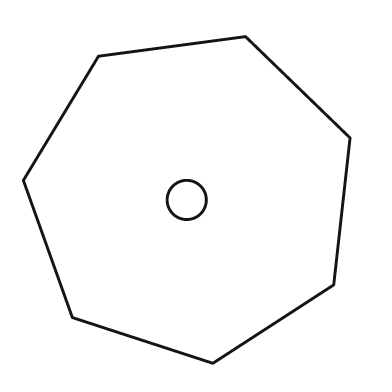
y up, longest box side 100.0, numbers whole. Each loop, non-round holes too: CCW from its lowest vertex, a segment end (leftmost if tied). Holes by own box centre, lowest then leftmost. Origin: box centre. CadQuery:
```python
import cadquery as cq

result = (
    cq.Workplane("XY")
    .moveTo(8.0, -50.0)
    .lineTo(45.0, -26.0)
    .lineTo(50.0, 19.0)
    .lineTo(18.0, 50.0)
    .lineTo(-27.0, 44.0)
    .lineTo(-50.0, 6.0)
    .lineTo(-35.0, -36.0)
    .close()
    .moveTo(0.0, 0.0)
    .circle(6.0)
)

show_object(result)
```